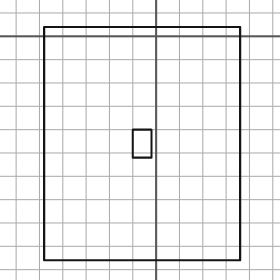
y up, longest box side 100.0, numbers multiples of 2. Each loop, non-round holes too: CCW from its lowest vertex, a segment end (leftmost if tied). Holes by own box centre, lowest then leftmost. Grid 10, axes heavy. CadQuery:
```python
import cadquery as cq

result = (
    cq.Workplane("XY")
    .moveTo(-48.0, -96.0)
    .lineTo(36.0, -96.0)
    .lineTo(36.0, 4.0)
    .lineTo(-48.0, 4.0)
    .close()
    .moveTo(-10.0, -52.0)
    .lineTo(-2.0, -52.0)
    .lineTo(-2.0, -40.0)
    .lineTo(-10.0, -40.0)
    .close()
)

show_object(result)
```